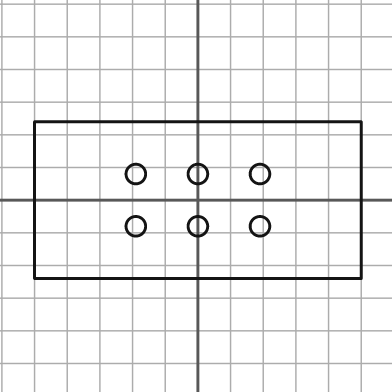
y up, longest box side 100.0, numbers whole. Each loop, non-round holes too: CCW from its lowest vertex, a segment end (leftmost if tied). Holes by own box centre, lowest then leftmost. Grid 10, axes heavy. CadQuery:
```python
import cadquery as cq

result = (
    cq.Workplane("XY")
    .moveTo(-50.0, -24.0)
    .lineTo(50.0, -24.0)
    .lineTo(50.0, 24.0)
    .lineTo(-50.0, 24.0)
    .close()
    .moveTo(-19.0, -8.0)
    .circle(3.0)
    .moveTo(0.0, -8.0)
    .circle(3.0)
    .moveTo(19.0, -8.0)
    .circle(3.0)
    .moveTo(-19.0, 8.0)
    .circle(3.0)
    .moveTo(0.0, 8.0)
    .circle(3.0)
    .moveTo(19.0, 8.0)
    .circle(3.0)
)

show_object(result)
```